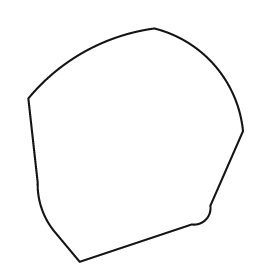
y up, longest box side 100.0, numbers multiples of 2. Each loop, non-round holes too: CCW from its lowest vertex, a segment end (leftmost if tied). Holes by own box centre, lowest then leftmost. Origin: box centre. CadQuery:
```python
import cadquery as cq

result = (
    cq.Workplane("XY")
    .moveTo(-24.0, -50.0)
    .lineTo(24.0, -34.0)
    .threePointArc((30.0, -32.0), (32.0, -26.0))
    .lineTo(46.0, 6.0)
    .threePointArc((34.0, 34.0), (8.0, 50.0))
    .threePointArc((-22.0, 40.0), (-46.0, 20.0))
    .lineTo(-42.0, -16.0)
    .threePointArc((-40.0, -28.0), (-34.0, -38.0))
    .close()
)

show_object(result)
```